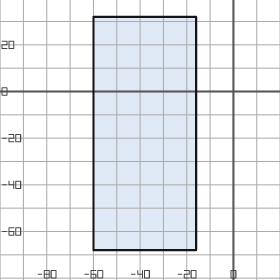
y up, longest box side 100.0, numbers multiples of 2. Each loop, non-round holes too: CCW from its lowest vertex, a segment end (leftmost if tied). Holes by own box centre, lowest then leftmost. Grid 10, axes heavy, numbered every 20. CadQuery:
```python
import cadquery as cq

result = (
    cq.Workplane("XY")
    .moveTo(-60.0, -68.0)
    .lineTo(-16.0, -68.0)
    .lineTo(-16.0, 32.0)
    .lineTo(-60.0, 32.0)
    .close()
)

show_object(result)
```